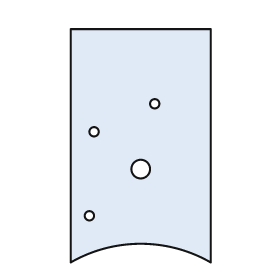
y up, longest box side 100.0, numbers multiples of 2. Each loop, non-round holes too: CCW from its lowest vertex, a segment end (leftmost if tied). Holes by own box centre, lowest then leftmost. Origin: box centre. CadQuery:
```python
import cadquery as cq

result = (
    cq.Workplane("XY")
    .moveTo(-30.0, -50.0)
    .threePointArc((0.0, -42.0), (30.0, -50.0))
    .lineTo(30.0, 50.0)
    .lineTo(-30.0, 50.0)
    .close()
    .moveTo(-22.0, -30.0)
    .circle(2.0)
    .moveTo(0.0, -10.0)
    .circle(4.0)
    .moveTo(-20.0, 6.0)
    .circle(2.0)
    .moveTo(6.0, 18.0)
    .circle(2.0)
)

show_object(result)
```